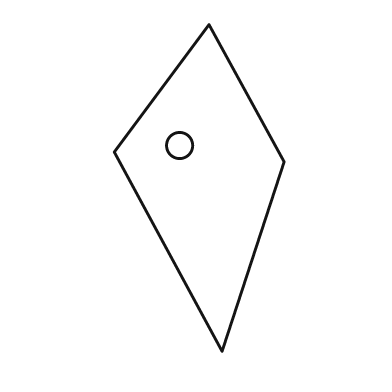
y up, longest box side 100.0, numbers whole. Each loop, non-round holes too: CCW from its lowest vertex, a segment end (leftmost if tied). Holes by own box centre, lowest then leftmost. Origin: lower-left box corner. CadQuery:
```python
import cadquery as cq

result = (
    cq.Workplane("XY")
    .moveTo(33.0, 0.0)
    .lineTo(52.0, 58.0)
    .lineTo(29.0, 100.0)
    .lineTo(0.0, 61.0)
    .close()
    .moveTo(20.0, 63.0)
    .circle(4.0)
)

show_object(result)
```